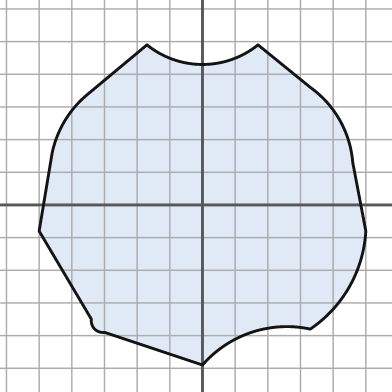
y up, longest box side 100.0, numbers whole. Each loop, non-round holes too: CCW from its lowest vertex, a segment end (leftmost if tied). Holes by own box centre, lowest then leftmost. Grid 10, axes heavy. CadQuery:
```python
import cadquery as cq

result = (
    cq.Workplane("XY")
    .moveTo(0.0, -49.0)
    .threePointArc((15.0, -39.0), (33.0, -38.0))
    .threePointArc((45.0, -25.0), (50.0, -8.0))
    .lineTo(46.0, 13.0)
    .threePointArc((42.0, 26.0), (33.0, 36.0))
    .lineTo(17.0, 49.0)
    .threePointArc((0.0, 43.0), (-17.0, 49.0))
    .lineTo(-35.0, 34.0)
    .threePointArc((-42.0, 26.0), (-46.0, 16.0))
    .lineTo(-50.0, -8.0)
    .lineTo(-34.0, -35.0)
    .threePointArc((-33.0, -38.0), (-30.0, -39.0))
    .close()
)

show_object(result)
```